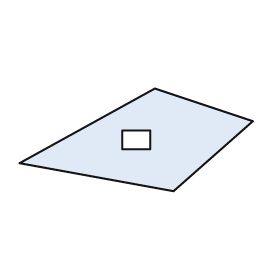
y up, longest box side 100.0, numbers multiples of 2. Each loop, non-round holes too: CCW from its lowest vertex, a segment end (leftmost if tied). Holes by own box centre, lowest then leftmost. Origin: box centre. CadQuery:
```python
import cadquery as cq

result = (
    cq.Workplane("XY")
    .moveTo(16.0, -22.0)
    .lineTo(50.0, 8.0)
    .lineTo(8.0, 22.0)
    .lineTo(-50.0, -10.0)
    .close()
    .moveTo(-6.0, -4.0)
    .lineTo(6.0, -4.0)
    .lineTo(6.0, 4.0)
    .lineTo(-6.0, 4.0)
    .close()
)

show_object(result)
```